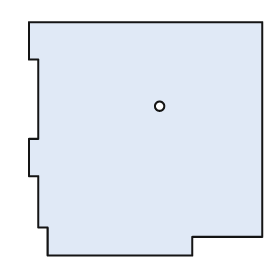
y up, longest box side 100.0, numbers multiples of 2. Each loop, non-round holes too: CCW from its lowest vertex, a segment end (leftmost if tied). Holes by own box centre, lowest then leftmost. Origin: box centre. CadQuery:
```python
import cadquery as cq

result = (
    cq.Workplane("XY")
    .moveTo(-42.0, -50.0)
    .lineTo(20.0, -50.0)
    .lineTo(20.0, -42.0)
    .lineTo(50.0, -42.0)
    .lineTo(50.0, 50.0)
    .lineTo(-50.0, 50.0)
    .lineTo(-50.0, 34.0)
    .lineTo(-46.0, 34.0)
    .lineTo(-46.0, 0.0)
    .lineTo(-50.0, 0.0)
    .lineTo(-50.0, -16.0)
    .lineTo(-46.0, -16.0)
    .lineTo(-46.0, -38.0)
    .lineTo(-42.0, -38.0)
    .close()
    .moveTo(6.0, 14.0)
    .circle(2.0)
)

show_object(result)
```